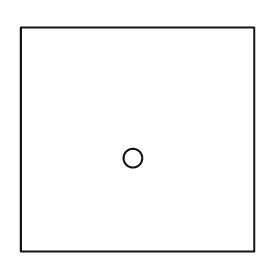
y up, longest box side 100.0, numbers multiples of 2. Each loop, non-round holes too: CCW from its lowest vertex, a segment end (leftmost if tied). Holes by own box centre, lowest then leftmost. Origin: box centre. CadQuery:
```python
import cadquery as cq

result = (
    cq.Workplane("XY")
    .moveTo(-50.0, -48.0)
    .lineTo(50.0, -48.0)
    .lineTo(50.0, 48.0)
    .lineTo(-50.0, 48.0)
    .close()
    .moveTo(-2.0, -8.0)
    .circle(4.0)
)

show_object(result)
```